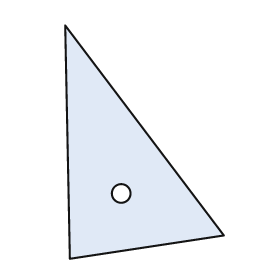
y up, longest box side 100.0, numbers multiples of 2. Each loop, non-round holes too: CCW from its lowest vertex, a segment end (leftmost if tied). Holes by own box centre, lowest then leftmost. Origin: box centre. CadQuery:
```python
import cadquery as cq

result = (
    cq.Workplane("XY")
    .moveTo(-32.0, -50.0)
    .lineTo(34.0, -40.0)
    .lineTo(-34.0, 50.0)
    .close()
    .moveTo(-10.0, -22.0)
    .circle(4.0)
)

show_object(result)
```